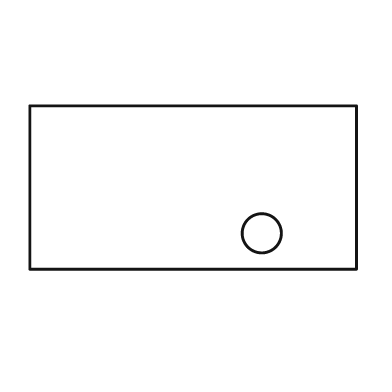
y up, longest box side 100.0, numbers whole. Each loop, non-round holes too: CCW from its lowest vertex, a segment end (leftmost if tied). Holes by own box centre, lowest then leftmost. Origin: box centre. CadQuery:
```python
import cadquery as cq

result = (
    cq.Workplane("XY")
    .moveTo(-50.0, -25.0)
    .lineTo(50.0, -25.0)
    .lineTo(50.0, 25.0)
    .lineTo(-50.0, 25.0)
    .close()
    .moveTo(21.0, -14.0)
    .circle(6.0)
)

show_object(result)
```